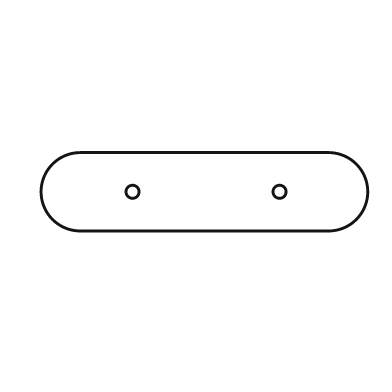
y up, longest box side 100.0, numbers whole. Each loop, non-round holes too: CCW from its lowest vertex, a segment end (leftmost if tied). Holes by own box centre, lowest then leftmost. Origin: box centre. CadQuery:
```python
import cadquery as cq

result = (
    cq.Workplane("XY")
    .moveTo(-38.0, -12.0)
    .lineTo(38.0, -12.0)
    .threePointArc((50.0, 0.0), (38.0, 12.0))
    .lineTo(-38.0, 12.0)
    .threePointArc((-50.0, 0.0), (-38.0, -12.0))
    .close()
    .moveTo(-22.0, 0.0)
    .circle(2.0)
    .moveTo(23.0, 0.0)
    .circle(2.0)
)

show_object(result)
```